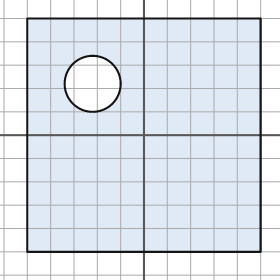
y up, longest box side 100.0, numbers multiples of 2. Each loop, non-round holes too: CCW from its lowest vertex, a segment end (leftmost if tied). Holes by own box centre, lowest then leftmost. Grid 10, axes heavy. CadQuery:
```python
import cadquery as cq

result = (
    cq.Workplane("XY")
    .moveTo(-50.0, -50.0)
    .lineTo(50.0, -50.0)
    .lineTo(50.0, 50.0)
    .lineTo(-50.0, 50.0)
    .close()
    .moveTo(-22.0, 22.0)
    .circle(12.0)
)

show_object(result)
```